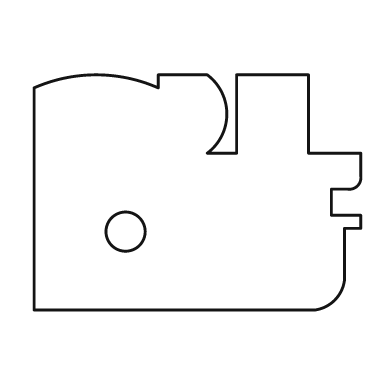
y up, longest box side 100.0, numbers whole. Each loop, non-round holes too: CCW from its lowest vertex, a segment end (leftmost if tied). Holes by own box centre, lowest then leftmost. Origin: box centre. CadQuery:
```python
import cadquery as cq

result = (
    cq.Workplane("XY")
    .moveTo(-50.0, -36.0)
    .lineTo(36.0, -36.0)
    .threePointArc((42.0, -33.0), (45.0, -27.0))
    .lineTo(45.0, -11.0)
    .lineTo(50.0, -11.0)
    .lineTo(50.0, -7.0)
    .lineTo(41.0, -7.0)
    .lineTo(41.0, 1.0)
    .lineTo(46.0, 1.0)
    .threePointArc((49.0, 2.0), (50.0, 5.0))
    .lineTo(50.0, 12.0)
    .lineTo(34.0, 12.0)
    .lineTo(34.0, 36.0)
    .lineTo(12.0, 36.0)
    .lineTo(12.0, 12.0)
    .lineTo(3.0, 12.0)
    .threePointArc((9.0, 24.0), (3.0, 36.0))
    .lineTo(-12.0, 36.0)
    .lineTo(-12.0, 32.0)
    .threePointArc((-31.0, 36.0), (-50.0, 32.0))
    .close()
    .moveTo(-22.0, -12.0)
    .circle(6.0)
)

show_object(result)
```